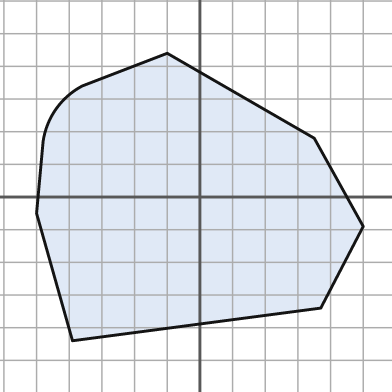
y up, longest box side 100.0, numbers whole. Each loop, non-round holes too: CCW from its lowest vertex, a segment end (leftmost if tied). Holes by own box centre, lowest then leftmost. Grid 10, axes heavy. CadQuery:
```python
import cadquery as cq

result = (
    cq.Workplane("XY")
    .moveTo(-39.0, -44.0)
    .lineTo(37.0, -34.0)
    .lineTo(50.0, -9.0)
    .lineTo(35.0, 18.0)
    .lineTo(-10.0, 44.0)
    .lineTo(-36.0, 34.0)
    .threePointArc((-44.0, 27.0), (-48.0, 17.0))
    .lineTo(-50.0, -5.0)
    .close()
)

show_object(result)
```